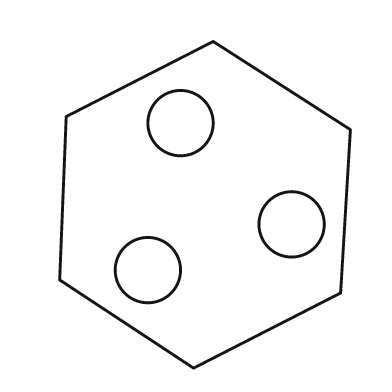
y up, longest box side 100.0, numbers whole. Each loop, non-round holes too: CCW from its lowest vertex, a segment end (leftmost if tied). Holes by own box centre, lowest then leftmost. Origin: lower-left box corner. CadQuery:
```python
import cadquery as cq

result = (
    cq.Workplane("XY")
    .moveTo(41.0, 0.0)
    .lineTo(86.0, 23.0)
    .lineTo(89.0, 73.0)
    .lineTo(47.0, 100.0)
    .lineTo(2.0, 77.0)
    .lineTo(0.0, 27.0)
    .close()
    .moveTo(27.0, 30.0)
    .circle(10.0)
    .moveTo(71.0, 44.0)
    .circle(10.0)
    .moveTo(37.0, 75.0)
    .circle(10.0)
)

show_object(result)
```